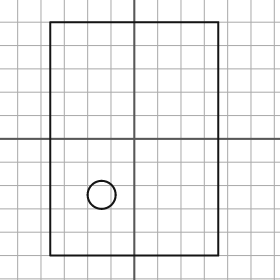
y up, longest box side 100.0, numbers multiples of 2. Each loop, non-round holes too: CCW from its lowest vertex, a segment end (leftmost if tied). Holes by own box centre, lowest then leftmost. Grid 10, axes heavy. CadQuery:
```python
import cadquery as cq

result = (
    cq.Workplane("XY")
    .moveTo(-36.0, -50.0)
    .lineTo(36.0, -50.0)
    .lineTo(36.0, 50.0)
    .lineTo(-36.0, 50.0)
    .close()
    .moveTo(-14.0, -24.0)
    .circle(6.0)
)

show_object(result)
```